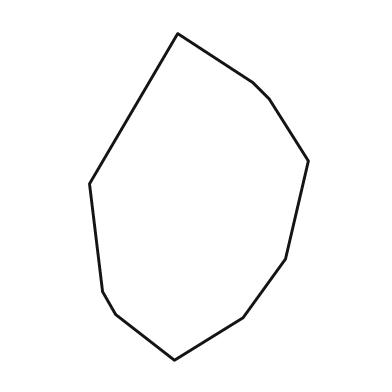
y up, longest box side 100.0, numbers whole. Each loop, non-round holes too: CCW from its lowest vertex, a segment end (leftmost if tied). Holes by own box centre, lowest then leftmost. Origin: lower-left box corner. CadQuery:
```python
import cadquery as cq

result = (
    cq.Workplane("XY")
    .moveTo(26.0, 0.0)
    .lineTo(47.0, 13.0)
    .lineTo(60.0, 31.0)
    .lineTo(67.0, 61.0)
    .lineTo(55.0, 80.0)
    .lineTo(50.0, 85.0)
    .lineTo(27.0, 100.0)
    .lineTo(0.0, 54.0)
    .lineTo(4.0, 21.0)
    .lineTo(8.0, 14.0)
    .close()
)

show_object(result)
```